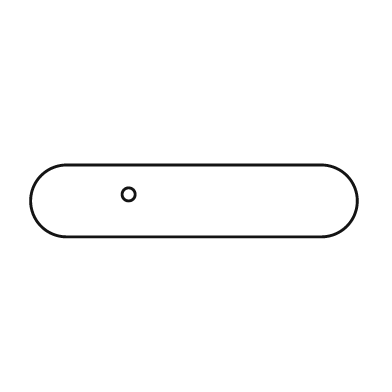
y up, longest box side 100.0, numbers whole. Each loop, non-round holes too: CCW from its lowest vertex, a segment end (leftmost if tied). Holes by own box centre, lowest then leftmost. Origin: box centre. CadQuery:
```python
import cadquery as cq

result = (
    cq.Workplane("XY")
    .moveTo(-39.0, -11.0)
    .lineTo(39.0, -11.0)
    .threePointArc((50.0, 0.0), (39.0, 11.0))
    .lineTo(-39.0, 11.0)
    .threePointArc((-50.0, 0.0), (-39.0, -11.0))
    .close()
    .moveTo(-20.0, 2.0)
    .circle(2.0)
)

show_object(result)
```